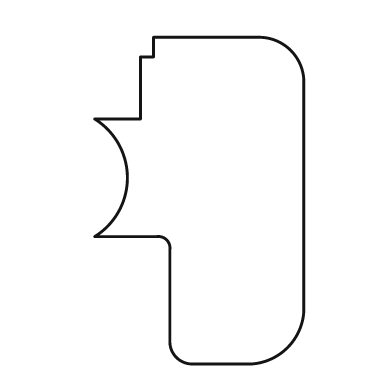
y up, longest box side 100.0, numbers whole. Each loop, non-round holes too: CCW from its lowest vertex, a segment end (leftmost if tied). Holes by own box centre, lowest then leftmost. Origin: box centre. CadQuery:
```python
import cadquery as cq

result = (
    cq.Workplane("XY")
    .moveTo(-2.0, -50.0)
    .lineTo(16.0, -50.0)
    .threePointArc((27.0, -45.0), (32.0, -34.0))
    .lineTo(32.0, 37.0)
    .threePointArc((28.0, 46.0), (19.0, 50.0))
    .lineTo(-14.0, 50.0)
    .lineTo(-14.0, 44.0)
    .lineTo(-18.0, 44.0)
    .lineTo(-18.0, 25.0)
    .lineTo(-32.0, 25.0)
    .threePointArc((-22.0, 7.0), (-32.0, -11.0))
    .lineTo(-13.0, -11.0)
    .threePointArc((-10.0, -12.0), (-9.0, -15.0))
    .lineTo(-9.0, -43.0)
    .threePointArc((-7.0, -48.0), (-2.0, -50.0))
    .close()
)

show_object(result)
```